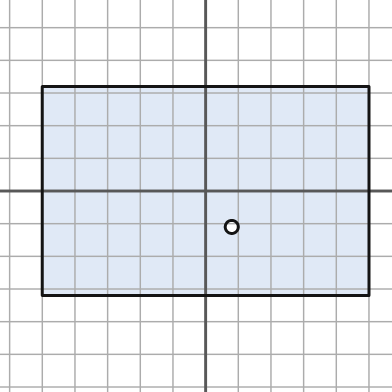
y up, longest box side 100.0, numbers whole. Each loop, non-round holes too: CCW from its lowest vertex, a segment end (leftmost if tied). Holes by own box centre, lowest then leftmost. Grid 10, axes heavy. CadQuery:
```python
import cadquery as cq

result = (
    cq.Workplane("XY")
    .moveTo(-50.0, -32.0)
    .lineTo(50.0, -32.0)
    .lineTo(50.0, 32.0)
    .lineTo(-50.0, 32.0)
    .close()
    .moveTo(8.0, -11.0)
    .circle(2.0)
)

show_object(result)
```